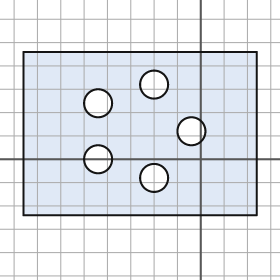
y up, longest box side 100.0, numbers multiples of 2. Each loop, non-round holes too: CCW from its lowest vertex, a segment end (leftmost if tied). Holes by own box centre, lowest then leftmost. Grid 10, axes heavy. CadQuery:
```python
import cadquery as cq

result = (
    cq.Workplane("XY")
    .moveTo(-76.0, -24.0)
    .lineTo(24.0, -24.0)
    .lineTo(24.0, 46.0)
    .lineTo(-76.0, 46.0)
    .close()
    .moveTo(-20.0, -8.0)
    .circle(6.0)
    .moveTo(-44.0, 0.0)
    .circle(6.0)
    .moveTo(-4.0, 12.0)
    .circle(6.0)
    .moveTo(-44.0, 24.0)
    .circle(6.0)
    .moveTo(-20.0, 32.0)
    .circle(6.0)
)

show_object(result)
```